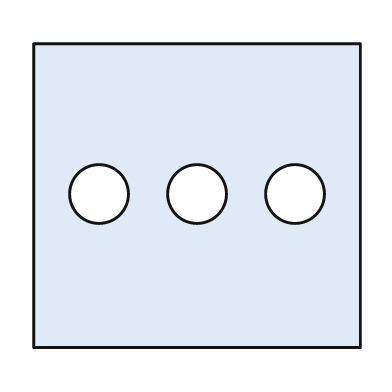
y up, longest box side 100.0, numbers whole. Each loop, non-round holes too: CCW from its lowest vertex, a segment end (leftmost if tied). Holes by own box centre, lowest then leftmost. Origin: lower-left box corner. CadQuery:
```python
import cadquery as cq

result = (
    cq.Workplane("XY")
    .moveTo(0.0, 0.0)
    .lineTo(100.0, 0.0)
    .lineTo(100.0, 93.0)
    .lineTo(0.0, 93.0)
    .close()
    .moveTo(20.0, 47.0)
    .circle(9.0)
    .moveTo(50.0, 47.0)
    .circle(9.0)
    .moveTo(80.0, 47.0)
    .circle(9.0)
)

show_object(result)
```